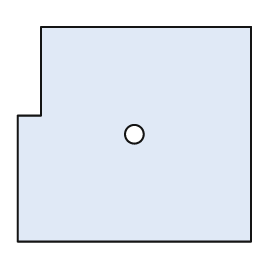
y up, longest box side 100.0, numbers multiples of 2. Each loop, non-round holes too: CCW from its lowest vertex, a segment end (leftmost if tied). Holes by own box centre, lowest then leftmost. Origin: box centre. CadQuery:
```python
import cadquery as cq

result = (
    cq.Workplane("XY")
    .moveTo(-50.0, -46.0)
    .lineTo(50.0, -46.0)
    .lineTo(50.0, 46.0)
    .lineTo(-40.0, 46.0)
    .lineTo(-40.0, 8.0)
    .lineTo(-50.0, 8.0)
    .close()
    .moveTo(0.0, 0.0)
    .circle(4.0)
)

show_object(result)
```